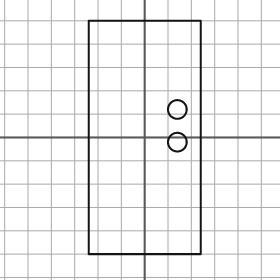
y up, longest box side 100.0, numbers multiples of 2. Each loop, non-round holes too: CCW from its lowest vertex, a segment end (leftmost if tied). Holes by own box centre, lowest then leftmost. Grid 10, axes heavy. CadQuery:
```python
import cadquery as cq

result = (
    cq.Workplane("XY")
    .moveTo(-24.0, -50.0)
    .lineTo(24.0, -50.0)
    .lineTo(24.0, 50.0)
    .lineTo(-24.0, 50.0)
    .close()
    .moveTo(14.0, -2.0)
    .circle(4.0)
    .moveTo(14.0, 12.0)
    .circle(4.0)
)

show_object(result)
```